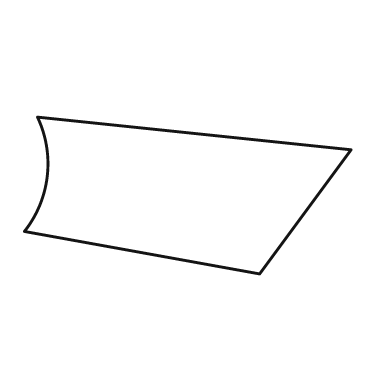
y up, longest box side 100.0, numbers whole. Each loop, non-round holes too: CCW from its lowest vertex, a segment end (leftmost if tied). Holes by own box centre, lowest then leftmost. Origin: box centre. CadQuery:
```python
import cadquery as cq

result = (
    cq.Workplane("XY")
    .moveTo(22.0, -24.0)
    .lineTo(50.0, 14.0)
    .lineTo(-46.0, 24.0)
    .threePointArc((-43.0, 6.0), (-50.0, -11.0))
    .close()
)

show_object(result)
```